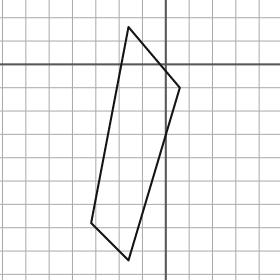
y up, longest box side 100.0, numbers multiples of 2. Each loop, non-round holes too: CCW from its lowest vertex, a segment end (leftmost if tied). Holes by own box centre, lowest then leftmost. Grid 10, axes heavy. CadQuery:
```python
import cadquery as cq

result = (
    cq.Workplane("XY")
    .moveTo(-16.0, -84.0)
    .lineTo(6.0, -10.0)
    .lineTo(-16.0, 16.0)
    .lineTo(-32.0, -68.0)
    .close()
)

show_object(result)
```